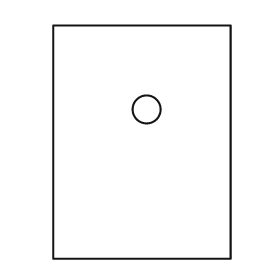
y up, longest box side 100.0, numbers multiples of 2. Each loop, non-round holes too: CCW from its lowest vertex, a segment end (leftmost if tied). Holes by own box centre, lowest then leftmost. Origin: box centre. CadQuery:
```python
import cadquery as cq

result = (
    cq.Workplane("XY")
    .moveTo(-38.0, -50.0)
    .lineTo(38.0, -50.0)
    .lineTo(38.0, 50.0)
    .lineTo(-38.0, 50.0)
    .close()
    .moveTo(2.0, 14.0)
    .circle(6.0)
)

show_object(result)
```